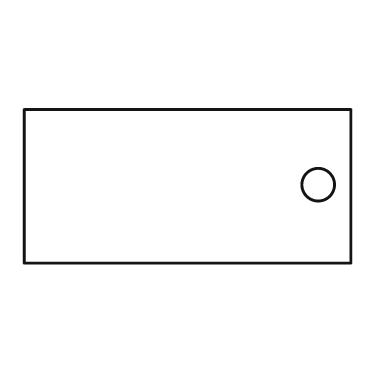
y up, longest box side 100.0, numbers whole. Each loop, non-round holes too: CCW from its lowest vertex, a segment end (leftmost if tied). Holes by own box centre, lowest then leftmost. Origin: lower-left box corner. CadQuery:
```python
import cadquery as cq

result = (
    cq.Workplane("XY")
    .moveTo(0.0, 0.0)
    .lineTo(100.0, 0.0)
    .lineTo(100.0, 47.0)
    .lineTo(0.0, 47.0)
    .close()
    .moveTo(90.0, 24.0)
    .circle(5.0)
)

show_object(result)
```